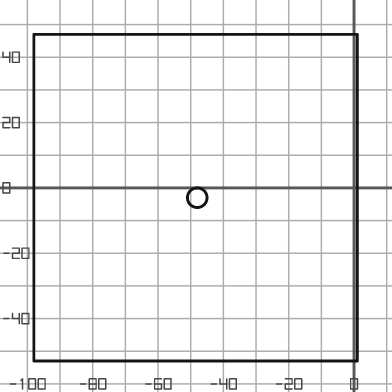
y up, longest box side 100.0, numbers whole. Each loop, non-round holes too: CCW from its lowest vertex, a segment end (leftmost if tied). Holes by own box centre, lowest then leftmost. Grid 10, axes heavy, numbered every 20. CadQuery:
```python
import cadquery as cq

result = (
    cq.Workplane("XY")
    .moveTo(-98.0, -53.0)
    .lineTo(1.0, -53.0)
    .lineTo(1.0, 47.0)
    .lineTo(-98.0, 47.0)
    .close()
    .moveTo(-48.0, -3.0)
    .circle(3.0)
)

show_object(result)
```